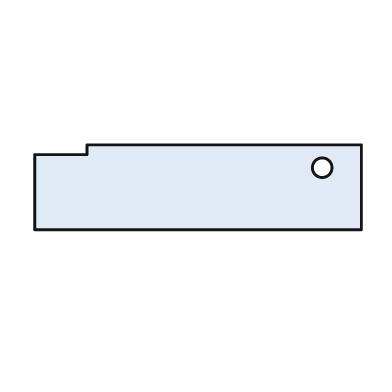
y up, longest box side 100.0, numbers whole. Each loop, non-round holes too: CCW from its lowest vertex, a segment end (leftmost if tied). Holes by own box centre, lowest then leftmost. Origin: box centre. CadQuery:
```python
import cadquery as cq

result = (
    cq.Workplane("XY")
    .moveTo(-50.0, -13.0)
    .lineTo(50.0, -13.0)
    .lineTo(50.0, 13.0)
    .lineTo(-34.0, 13.0)
    .lineTo(-34.0, 10.0)
    .lineTo(-50.0, 10.0)
    .close()
    .moveTo(38.0, 6.0)
    .circle(3.0)
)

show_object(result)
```